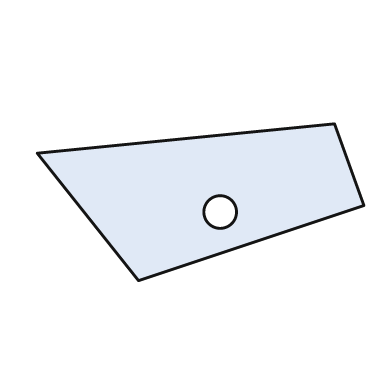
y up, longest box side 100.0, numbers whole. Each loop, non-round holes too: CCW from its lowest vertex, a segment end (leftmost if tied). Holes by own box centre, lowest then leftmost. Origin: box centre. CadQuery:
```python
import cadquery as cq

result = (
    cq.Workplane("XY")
    .moveTo(-19.0, -24.0)
    .lineTo(50.0, -1.0)
    .lineTo(41.0, 24.0)
    .lineTo(-50.0, 15.0)
    .close()
    .moveTo(6.0, -3.0)
    .circle(5.0)
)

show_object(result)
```